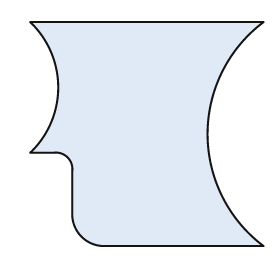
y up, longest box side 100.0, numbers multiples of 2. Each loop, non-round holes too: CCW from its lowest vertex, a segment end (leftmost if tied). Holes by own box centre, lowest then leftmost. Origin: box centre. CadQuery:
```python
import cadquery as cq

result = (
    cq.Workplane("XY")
    .moveTo(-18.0, -48.0)
    .lineTo(50.0, -48.0)
    .threePointArc((26.0, 0.0), (50.0, 48.0))
    .lineTo(-50.0, 48.0)
    .threePointArc((-38.0, 20.0), (-50.0, -8.0))
    .lineTo(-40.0, -8.0)
    .threePointArc((-34.0, -10.0), (-32.0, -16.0))
    .lineTo(-32.0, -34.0)
    .threePointArc((-28.0, -44.0), (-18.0, -48.0))
    .close()
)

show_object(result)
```